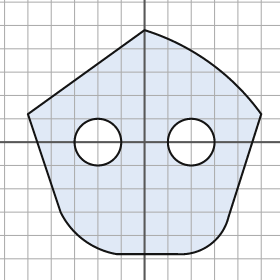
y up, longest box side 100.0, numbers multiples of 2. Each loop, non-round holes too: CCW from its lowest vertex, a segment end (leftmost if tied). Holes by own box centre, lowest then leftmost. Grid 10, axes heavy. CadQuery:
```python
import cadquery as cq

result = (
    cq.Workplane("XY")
    .moveTo(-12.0, -48.0)
    .lineTo(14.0, -48.0)
    .threePointArc((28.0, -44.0), (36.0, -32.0))
    .lineTo(50.0, 12.0)
    .threePointArc((28.0, 34.0), (0.0, 48.0))
    .lineTo(-50.0, 12.0)
    .lineTo(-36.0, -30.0)
    .threePointArc((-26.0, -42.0), (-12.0, -48.0))
    .close()
    .moveTo(-20.0, 0.0)
    .circle(10.0)
    .moveTo(20.0, 0.0)
    .circle(10.0)
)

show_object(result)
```